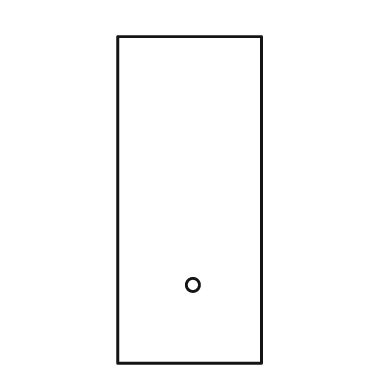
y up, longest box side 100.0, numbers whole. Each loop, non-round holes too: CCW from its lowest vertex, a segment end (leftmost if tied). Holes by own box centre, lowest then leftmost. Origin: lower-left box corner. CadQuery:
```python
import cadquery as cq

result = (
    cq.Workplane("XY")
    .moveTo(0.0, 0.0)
    .lineTo(44.0, 0.0)
    .lineTo(44.0, 100.0)
    .lineTo(0.0, 100.0)
    .close()
    .moveTo(23.0, 24.0)
    .circle(2.0)
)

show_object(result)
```